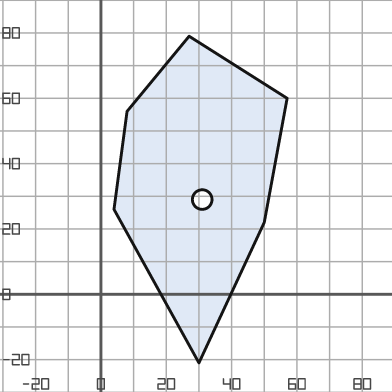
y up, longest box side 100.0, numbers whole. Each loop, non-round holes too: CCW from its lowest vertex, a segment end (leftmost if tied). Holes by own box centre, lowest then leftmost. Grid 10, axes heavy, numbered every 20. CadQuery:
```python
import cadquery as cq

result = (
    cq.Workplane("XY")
    .moveTo(30.0, -21.0)
    .lineTo(50.0, 22.0)
    .lineTo(57.0, 60.0)
    .lineTo(27.0, 79.0)
    .lineTo(8.0, 56.0)
    .lineTo(4.0, 26.0)
    .close()
    .moveTo(31.0, 29.0)
    .circle(3.0)
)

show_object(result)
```